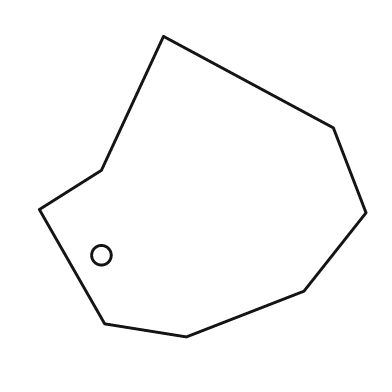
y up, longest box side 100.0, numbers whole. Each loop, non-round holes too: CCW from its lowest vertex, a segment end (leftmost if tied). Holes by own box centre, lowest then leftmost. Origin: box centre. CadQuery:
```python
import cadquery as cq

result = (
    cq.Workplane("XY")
    .moveTo(-5.0, -46.0)
    .lineTo(31.0, -32.0)
    .lineTo(50.0, -8.0)
    .lineTo(40.0, 18.0)
    .lineTo(-12.0, 46.0)
    .lineTo(-31.0, 5.0)
    .lineTo(-50.0, -7.0)
    .lineTo(-30.0, -42.0)
    .close()
    .moveTo(-31.0, -21.0)
    .circle(3.0)
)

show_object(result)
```